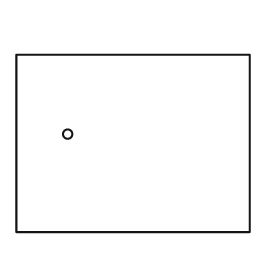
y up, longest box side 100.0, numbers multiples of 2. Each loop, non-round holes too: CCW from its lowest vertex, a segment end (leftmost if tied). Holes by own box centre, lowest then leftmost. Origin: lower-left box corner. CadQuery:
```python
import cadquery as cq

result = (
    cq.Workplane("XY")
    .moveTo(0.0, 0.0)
    .lineTo(100.0, 0.0)
    .lineTo(100.0, 76.0)
    .lineTo(0.0, 76.0)
    .close()
    .moveTo(22.0, 42.0)
    .circle(2.0)
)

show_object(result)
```